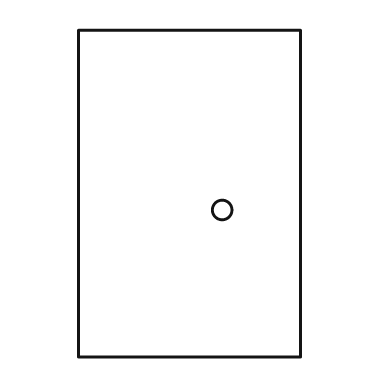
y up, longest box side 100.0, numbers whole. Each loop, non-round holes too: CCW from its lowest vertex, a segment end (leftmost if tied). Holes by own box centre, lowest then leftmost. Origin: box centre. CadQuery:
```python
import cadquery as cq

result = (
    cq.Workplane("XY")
    .moveTo(-34.0, -50.0)
    .lineTo(34.0, -50.0)
    .lineTo(34.0, 50.0)
    .lineTo(-34.0, 50.0)
    .close()
    .moveTo(10.0, -5.0)
    .circle(3.0)
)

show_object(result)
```